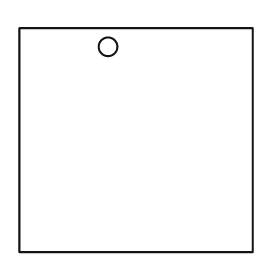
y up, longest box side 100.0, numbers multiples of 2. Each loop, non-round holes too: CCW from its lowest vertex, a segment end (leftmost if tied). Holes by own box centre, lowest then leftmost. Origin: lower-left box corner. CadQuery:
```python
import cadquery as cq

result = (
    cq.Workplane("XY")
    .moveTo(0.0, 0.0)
    .lineTo(100.0, 0.0)
    .lineTo(100.0, 96.0)
    .lineTo(0.0, 96.0)
    .close()
    .moveTo(38.0, 88.0)
    .circle(4.0)
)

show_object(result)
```